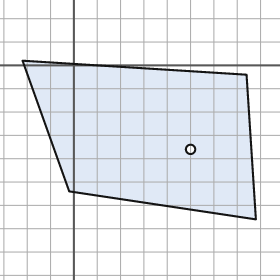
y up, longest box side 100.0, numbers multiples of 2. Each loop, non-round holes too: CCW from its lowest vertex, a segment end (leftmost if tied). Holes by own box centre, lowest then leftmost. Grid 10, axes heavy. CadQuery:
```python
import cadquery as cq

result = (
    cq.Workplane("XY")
    .moveTo(78.0, -66.0)
    .lineTo(74.0, -4.0)
    .lineTo(-22.0, 2.0)
    .lineTo(-2.0, -54.0)
    .close()
    .moveTo(50.0, -36.0)
    .circle(2.0)
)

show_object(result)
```